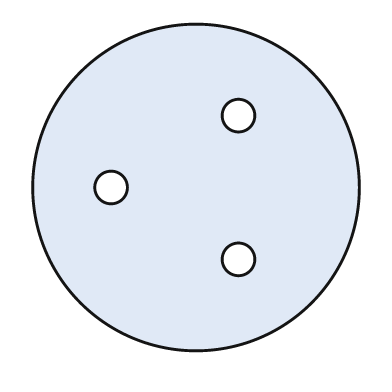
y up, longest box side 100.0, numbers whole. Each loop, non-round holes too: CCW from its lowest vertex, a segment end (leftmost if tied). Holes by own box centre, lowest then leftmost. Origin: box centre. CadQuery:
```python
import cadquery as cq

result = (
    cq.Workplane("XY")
    .moveTo(0.0, 0.0)
    .circle(50.0)
    .moveTo(13.0, -22.0)
    .circle(5.0)
    .moveTo(-26.0, 0.0)
    .circle(5.0)
    .moveTo(13.0, 22.0)
    .circle(5.0)
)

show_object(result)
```